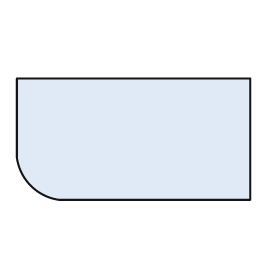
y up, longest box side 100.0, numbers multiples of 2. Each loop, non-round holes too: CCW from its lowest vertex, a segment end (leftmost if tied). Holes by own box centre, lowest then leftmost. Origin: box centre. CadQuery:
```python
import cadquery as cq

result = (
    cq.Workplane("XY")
    .moveTo(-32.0, -26.0)
    .lineTo(50.0, -26.0)
    .lineTo(50.0, 26.0)
    .lineTo(-50.0, 26.0)
    .lineTo(-50.0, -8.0)
    .threePointArc((-44.0, -20.0), (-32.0, -26.0))
    .close()
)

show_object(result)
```